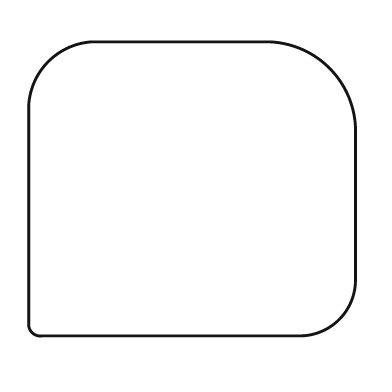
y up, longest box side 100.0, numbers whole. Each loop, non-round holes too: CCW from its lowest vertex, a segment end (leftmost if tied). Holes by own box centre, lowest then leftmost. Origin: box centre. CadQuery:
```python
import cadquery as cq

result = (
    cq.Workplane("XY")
    .moveTo(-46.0, -45.0)
    .lineTo(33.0, -45.0)
    .threePointArc((45.0, -40.0), (50.0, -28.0))
    .lineTo(50.0, 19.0)
    .threePointArc((42.0, 37.0), (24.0, 45.0))
    .lineTo(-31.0, 45.0)
    .threePointArc((-44.0, 39.0), (-50.0, 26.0))
    .lineTo(-50.0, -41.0)
    .threePointArc((-49.0, -44.0), (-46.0, -45.0))
    .close()
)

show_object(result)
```